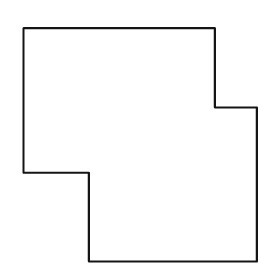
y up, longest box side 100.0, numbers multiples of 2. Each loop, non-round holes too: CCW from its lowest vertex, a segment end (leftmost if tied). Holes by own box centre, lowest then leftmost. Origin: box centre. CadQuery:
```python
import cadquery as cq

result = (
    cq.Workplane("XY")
    .moveTo(-22.0, -50.0)
    .lineTo(50.0, -50.0)
    .lineTo(50.0, 16.0)
    .lineTo(32.0, 16.0)
    .lineTo(32.0, 50.0)
    .lineTo(-50.0, 50.0)
    .lineTo(-50.0, -12.0)
    .lineTo(-22.0, -12.0)
    .close()
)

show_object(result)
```